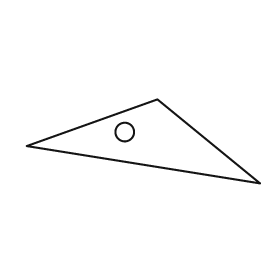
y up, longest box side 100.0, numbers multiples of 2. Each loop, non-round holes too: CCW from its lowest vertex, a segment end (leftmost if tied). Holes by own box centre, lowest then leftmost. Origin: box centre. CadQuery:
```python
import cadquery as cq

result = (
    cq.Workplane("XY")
    .moveTo(50.0, -18.0)
    .lineTo(6.0, 18.0)
    .lineTo(-50.0, -2.0)
    .close()
    .moveTo(-8.0, 4.0)
    .circle(4.0)
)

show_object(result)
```